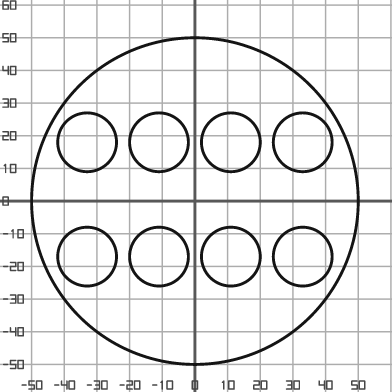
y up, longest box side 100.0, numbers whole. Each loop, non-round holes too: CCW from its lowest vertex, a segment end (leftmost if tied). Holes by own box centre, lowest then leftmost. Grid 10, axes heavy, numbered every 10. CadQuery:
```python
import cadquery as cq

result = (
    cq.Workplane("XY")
    .moveTo(0.0, 0.0)
    .circle(50.0)
    .moveTo(-33.0, -17.0)
    .circle(9.0)
    .moveTo(-11.0, -17.0)
    .circle(9.0)
    .moveTo(11.0, -17.0)
    .circle(9.0)
    .moveTo(33.0, -17.0)
    .circle(9.0)
    .moveTo(-33.0, 18.0)
    .circle(9.0)
    .moveTo(-11.0, 18.0)
    .circle(9.0)
    .moveTo(11.0, 18.0)
    .circle(9.0)
    .moveTo(33.0, 18.0)
    .circle(9.0)
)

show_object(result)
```